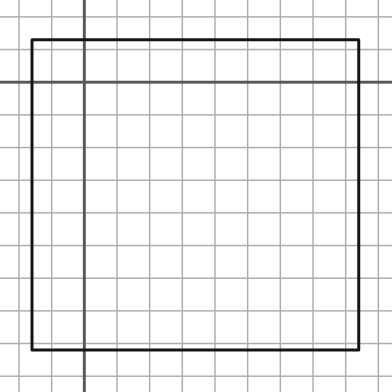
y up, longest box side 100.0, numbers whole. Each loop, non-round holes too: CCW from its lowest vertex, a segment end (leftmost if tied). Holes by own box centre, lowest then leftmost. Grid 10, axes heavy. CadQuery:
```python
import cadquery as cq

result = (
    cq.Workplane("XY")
    .moveTo(-16.0, -82.0)
    .lineTo(84.0, -82.0)
    .lineTo(84.0, 13.0)
    .lineTo(-16.0, 13.0)
    .close()
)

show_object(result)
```